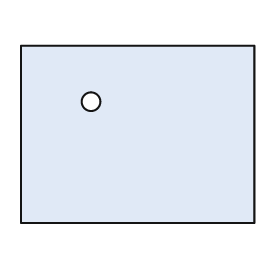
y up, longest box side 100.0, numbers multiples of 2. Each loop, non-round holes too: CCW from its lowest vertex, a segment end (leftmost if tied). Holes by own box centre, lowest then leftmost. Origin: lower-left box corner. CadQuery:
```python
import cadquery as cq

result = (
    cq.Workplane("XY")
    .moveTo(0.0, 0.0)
    .lineTo(100.0, 0.0)
    .lineTo(100.0, 76.0)
    .lineTo(0.0, 76.0)
    .close()
    .moveTo(30.0, 52.0)
    .circle(4.0)
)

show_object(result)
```